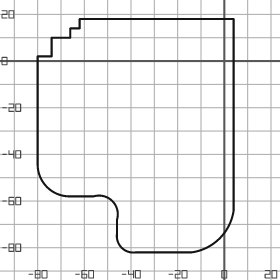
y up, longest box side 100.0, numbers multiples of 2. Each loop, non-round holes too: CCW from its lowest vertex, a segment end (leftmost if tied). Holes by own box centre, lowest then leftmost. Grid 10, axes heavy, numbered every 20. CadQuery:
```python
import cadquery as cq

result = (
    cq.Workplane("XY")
    .moveTo(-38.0, -82.0)
    .lineTo(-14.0, -82.0)
    .threePointArc((-2.0, -76.0), (4.0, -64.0))
    .lineTo(4.0, 18.0)
    .lineTo(-62.0, 18.0)
    .lineTo(-62.0, 14.0)
    .lineTo(-66.0, 14.0)
    .lineTo(-66.0, 10.0)
    .lineTo(-74.0, 10.0)
    .lineTo(-74.0, 2.0)
    .lineTo(-80.0, 2.0)
    .lineTo(-80.0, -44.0)
    .threePointArc((-76.0, -54.0), (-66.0, -58.0))
    .lineTo(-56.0, -58.0)
    .threePointArc((-48.0, -60.0), (-46.0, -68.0))
    .lineTo(-46.0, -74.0)
    .threePointArc((-44.0, -80.0), (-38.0, -82.0))
    .close()
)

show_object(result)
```